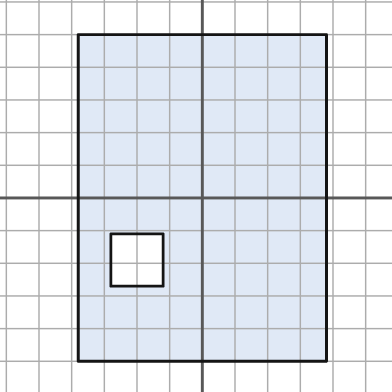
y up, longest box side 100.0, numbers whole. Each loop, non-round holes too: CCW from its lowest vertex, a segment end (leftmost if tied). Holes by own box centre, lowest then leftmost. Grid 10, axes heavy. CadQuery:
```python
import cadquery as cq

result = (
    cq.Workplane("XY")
    .moveTo(-38.0, -50.0)
    .lineTo(38.0, -50.0)
    .lineTo(38.0, 50.0)
    .lineTo(-38.0, 50.0)
    .close()
    .moveTo(-28.0, -27.0)
    .lineTo(-12.0, -27.0)
    .lineTo(-12.0, -11.0)
    .lineTo(-28.0, -11.0)
    .close()
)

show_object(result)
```